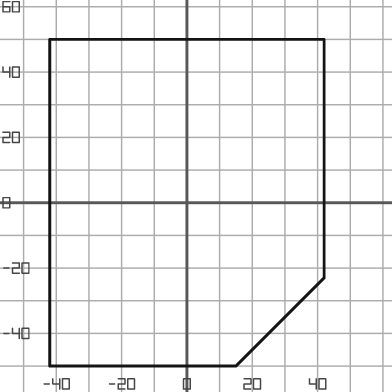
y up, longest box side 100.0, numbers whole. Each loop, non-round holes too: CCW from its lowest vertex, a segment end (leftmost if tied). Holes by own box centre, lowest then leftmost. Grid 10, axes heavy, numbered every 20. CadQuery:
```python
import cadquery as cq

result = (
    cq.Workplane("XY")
    .moveTo(-42.0, -50.0)
    .lineTo(15.0, -50.0)
    .lineTo(42.0, -23.0)
    .lineTo(42.0, 50.0)
    .lineTo(-42.0, 50.0)
    .close()
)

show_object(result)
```